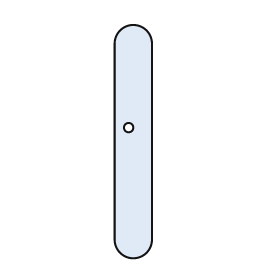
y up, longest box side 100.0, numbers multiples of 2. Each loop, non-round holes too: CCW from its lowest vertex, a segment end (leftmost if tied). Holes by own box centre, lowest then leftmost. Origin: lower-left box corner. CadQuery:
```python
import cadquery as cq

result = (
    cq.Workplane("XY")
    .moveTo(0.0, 8.0)
    .threePointArc((8.0, 0.0), (16.0, 8.0))
    .lineTo(16.0, 92.0)
    .threePointArc((8.0, 100.0), (0.0, 92.0))
    .close()
    .moveTo(6.0, 56.0)
    .circle(2.0)
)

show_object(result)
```